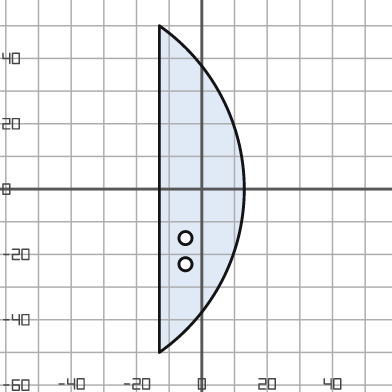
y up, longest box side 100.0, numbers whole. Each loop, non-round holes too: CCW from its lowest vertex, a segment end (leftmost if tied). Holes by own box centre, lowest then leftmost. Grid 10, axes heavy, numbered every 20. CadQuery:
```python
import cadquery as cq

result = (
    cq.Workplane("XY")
    .moveTo(-13.0, -50.0)
    .threePointArc((13.0, 0.0), (-13.0, 50.0))
    .close()
    .moveTo(-5.0, -23.0)
    .circle(2.0)
    .moveTo(-5.0, -15.0)
    .circle(2.0)
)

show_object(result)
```